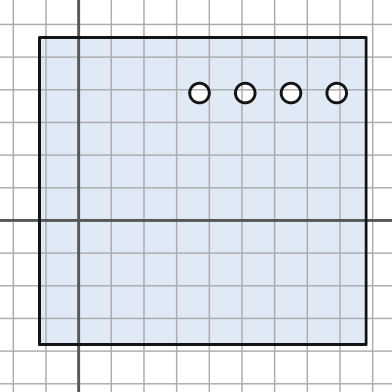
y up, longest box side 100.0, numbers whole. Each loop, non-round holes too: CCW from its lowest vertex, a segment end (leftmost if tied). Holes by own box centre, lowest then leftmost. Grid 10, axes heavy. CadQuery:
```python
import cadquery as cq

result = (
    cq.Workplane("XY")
    .moveTo(-12.0, -38.0)
    .lineTo(88.0, -38.0)
    .lineTo(88.0, 56.0)
    .lineTo(-12.0, 56.0)
    .close()
    .moveTo(37.0, 39.0)
    .circle(3.0)
    .moveTo(51.0, 39.0)
    .circle(3.0)
    .moveTo(65.0, 39.0)
    .circle(3.0)
    .moveTo(79.0, 39.0)
    .circle(3.0)
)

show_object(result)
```